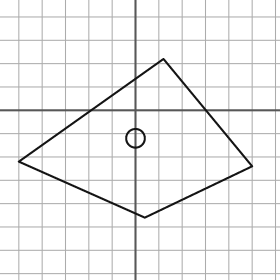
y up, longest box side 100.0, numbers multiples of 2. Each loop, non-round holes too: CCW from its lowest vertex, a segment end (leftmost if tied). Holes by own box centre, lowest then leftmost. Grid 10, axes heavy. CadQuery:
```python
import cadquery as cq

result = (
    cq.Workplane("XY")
    .moveTo(4.0, -46.0)
    .lineTo(50.0, -24.0)
    .lineTo(12.0, 22.0)
    .lineTo(-50.0, -22.0)
    .close()
    .moveTo(0.0, -12.0)
    .circle(4.0)
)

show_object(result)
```